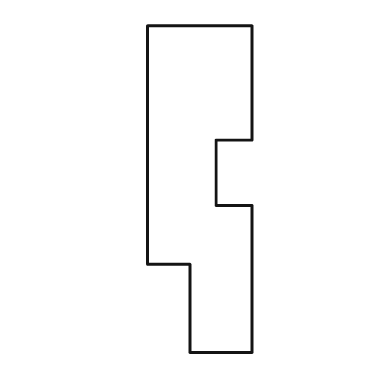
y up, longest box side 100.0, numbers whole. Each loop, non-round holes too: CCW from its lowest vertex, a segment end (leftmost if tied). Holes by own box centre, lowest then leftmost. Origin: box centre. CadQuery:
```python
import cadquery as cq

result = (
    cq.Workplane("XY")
    .moveTo(-3.0, -50.0)
    .lineTo(16.0, -50.0)
    .lineTo(16.0, -5.0)
    .lineTo(5.0, -5.0)
    .lineTo(5.0, 15.0)
    .lineTo(16.0, 15.0)
    .lineTo(16.0, 50.0)
    .lineTo(-16.0, 50.0)
    .lineTo(-16.0, -23.0)
    .lineTo(-3.0, -23.0)
    .close()
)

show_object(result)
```